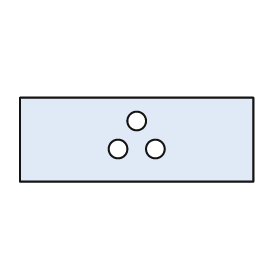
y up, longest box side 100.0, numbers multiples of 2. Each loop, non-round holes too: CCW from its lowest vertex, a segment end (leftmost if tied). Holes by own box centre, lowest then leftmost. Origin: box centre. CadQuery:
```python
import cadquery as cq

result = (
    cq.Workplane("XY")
    .moveTo(-50.0, -18.0)
    .lineTo(50.0, -18.0)
    .lineTo(50.0, 18.0)
    .lineTo(-50.0, 18.0)
    .close()
    .moveTo(-8.0, -4.0)
    .circle(4.0)
    .moveTo(8.0, -4.0)
    .circle(4.0)
    .moveTo(0.0, 8.0)
    .circle(4.0)
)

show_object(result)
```